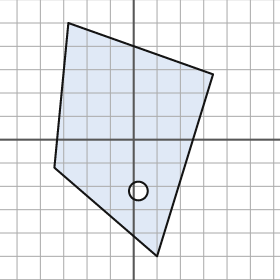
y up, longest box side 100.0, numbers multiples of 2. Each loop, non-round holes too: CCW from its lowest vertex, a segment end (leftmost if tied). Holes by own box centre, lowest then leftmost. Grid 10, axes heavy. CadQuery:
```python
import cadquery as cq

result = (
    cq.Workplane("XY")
    .moveTo(10.0, -50.0)
    .lineTo(34.0, 28.0)
    .lineTo(-28.0, 50.0)
    .lineTo(-34.0, -12.0)
    .close()
    .moveTo(2.0, -22.0)
    .circle(4.0)
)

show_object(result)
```